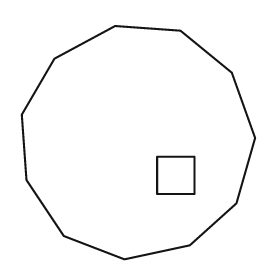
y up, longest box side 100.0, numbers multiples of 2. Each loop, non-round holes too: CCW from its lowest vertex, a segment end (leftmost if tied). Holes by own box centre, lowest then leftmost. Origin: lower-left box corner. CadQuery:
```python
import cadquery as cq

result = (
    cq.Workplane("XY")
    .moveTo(44.0, 0.0)
    .lineTo(72.0, 6.0)
    .lineTo(92.0, 24.0)
    .lineTo(100.0, 52.0)
    .lineTo(90.0, 80.0)
    .lineTo(68.0, 98.0)
    .lineTo(40.0, 100.0)
    .lineTo(14.0, 86.0)
    .lineTo(0.0, 62.0)
    .lineTo(2.0, 34.0)
    .lineTo(18.0, 10.0)
    .close()
    .moveTo(58.0, 28.0)
    .lineTo(74.0, 28.0)
    .lineTo(74.0, 44.0)
    .lineTo(58.0, 44.0)
    .close()
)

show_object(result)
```